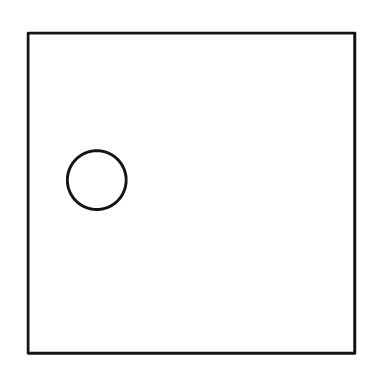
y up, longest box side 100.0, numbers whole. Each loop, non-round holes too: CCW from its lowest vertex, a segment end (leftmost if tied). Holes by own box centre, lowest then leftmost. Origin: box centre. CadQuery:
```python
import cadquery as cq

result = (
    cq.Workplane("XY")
    .moveTo(-50.0, -49.0)
    .lineTo(50.0, -49.0)
    .lineTo(50.0, 49.0)
    .lineTo(-50.0, 49.0)
    .close()
    .moveTo(-29.0, 4.0)
    .circle(9.0)
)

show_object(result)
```